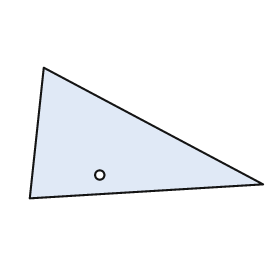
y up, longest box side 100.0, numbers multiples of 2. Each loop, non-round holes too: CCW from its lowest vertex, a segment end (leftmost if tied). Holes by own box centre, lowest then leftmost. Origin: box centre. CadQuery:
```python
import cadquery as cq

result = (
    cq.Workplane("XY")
    .moveTo(-50.0, -28.0)
    .lineTo(50.0, -22.0)
    .lineTo(-44.0, 28.0)
    .close()
    .moveTo(-20.0, -18.0)
    .circle(2.0)
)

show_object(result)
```